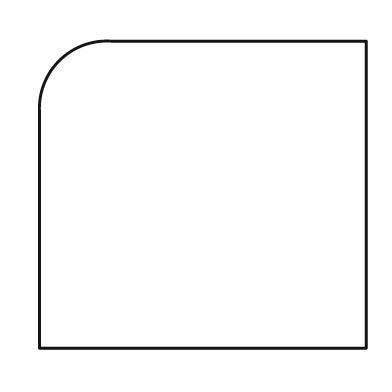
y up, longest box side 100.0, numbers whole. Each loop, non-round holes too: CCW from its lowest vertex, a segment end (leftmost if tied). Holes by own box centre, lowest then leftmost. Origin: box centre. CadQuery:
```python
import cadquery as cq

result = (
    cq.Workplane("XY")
    .moveTo(-50.0, -47.0)
    .lineTo(50.0, -47.0)
    .lineTo(50.0, 47.0)
    .lineTo(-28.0, 47.0)
    .threePointArc((-44.0, 41.0), (-50.0, 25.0))
    .close()
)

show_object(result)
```